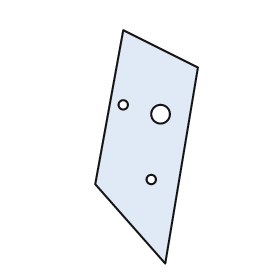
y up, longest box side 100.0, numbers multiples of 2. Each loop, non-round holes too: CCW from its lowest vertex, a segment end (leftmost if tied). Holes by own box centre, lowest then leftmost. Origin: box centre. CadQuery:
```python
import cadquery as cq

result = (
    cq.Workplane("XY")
    .moveTo(8.0, -50.0)
    .lineTo(22.0, 34.0)
    .lineTo(-10.0, 50.0)
    .lineTo(-22.0, -16.0)
    .close()
    .moveTo(2.0, -14.0)
    .circle(2.0)
    .moveTo(6.0, 14.0)
    .circle(4.0)
    .moveTo(-10.0, 18.0)
    .circle(2.0)
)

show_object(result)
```